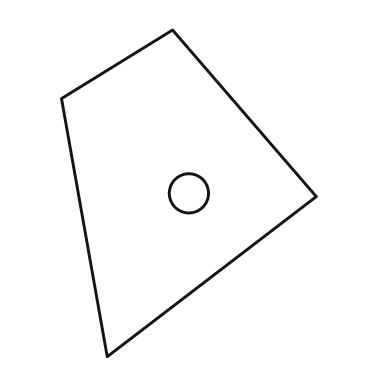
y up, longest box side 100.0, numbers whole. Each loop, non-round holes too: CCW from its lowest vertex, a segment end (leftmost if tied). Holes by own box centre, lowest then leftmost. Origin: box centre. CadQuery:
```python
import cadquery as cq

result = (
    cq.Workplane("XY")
    .moveTo(-25.0, -50.0)
    .lineTo(39.0, -1.0)
    .lineTo(-5.0, 50.0)
    .lineTo(-39.0, 29.0)
    .close()
    .moveTo(0.0, 0.0)
    .circle(6.0)
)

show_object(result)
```